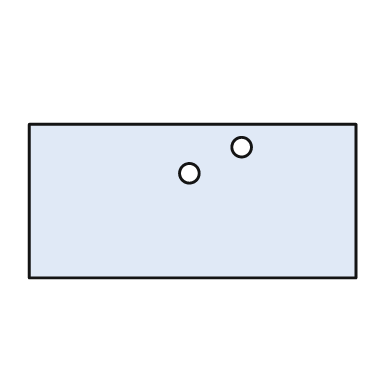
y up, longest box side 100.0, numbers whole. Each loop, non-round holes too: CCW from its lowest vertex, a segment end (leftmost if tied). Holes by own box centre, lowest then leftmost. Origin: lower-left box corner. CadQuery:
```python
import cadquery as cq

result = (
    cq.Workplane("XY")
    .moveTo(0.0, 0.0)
    .lineTo(100.0, 0.0)
    .lineTo(100.0, 47.0)
    .lineTo(0.0, 47.0)
    .close()
    .moveTo(49.0, 32.0)
    .circle(3.0)
    .moveTo(65.0, 40.0)
    .circle(3.0)
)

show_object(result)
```